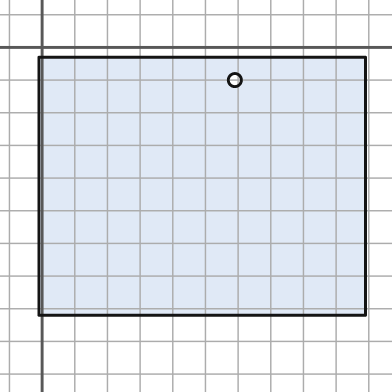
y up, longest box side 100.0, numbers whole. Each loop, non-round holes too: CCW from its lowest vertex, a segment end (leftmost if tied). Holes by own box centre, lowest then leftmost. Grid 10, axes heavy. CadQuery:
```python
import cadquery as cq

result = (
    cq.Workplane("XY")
    .moveTo(-1.0, -82.0)
    .lineTo(99.0, -82.0)
    .lineTo(99.0, -3.0)
    .lineTo(-1.0, -3.0)
    .close()
    .moveTo(59.0, -10.0)
    .circle(2.0)
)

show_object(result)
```